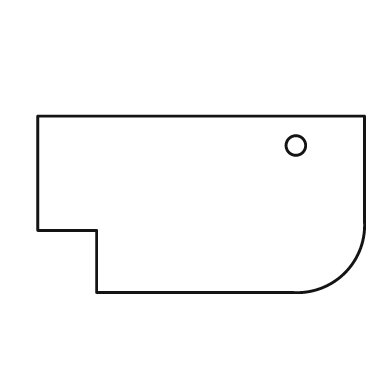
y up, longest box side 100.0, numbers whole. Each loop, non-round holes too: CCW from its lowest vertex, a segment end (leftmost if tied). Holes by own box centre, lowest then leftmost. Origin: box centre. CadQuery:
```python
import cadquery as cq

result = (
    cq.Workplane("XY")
    .moveTo(-32.0, -27.0)
    .lineTo(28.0, -27.0)
    .threePointArc((44.0, -21.0), (50.0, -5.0))
    .lineTo(50.0, 27.0)
    .lineTo(-50.0, 27.0)
    .lineTo(-50.0, -8.0)
    .lineTo(-32.0, -8.0)
    .close()
    .moveTo(29.0, 18.0)
    .circle(3.0)
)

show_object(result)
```